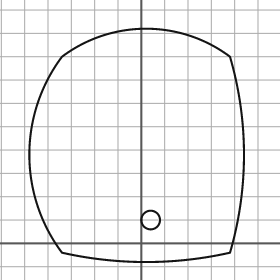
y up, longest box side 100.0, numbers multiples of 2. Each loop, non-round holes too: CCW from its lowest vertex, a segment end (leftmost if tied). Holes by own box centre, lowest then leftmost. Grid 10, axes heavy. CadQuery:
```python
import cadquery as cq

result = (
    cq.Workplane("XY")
    .moveTo(-34.0, -4.0)
    .threePointArc((2.0, -8.0), (38.0, -4.0))
    .threePointArc((44.0, 38.0), (38.0, 80.0))
    .threePointArc((2.0, 92.0), (-34.0, 80.0))
    .threePointArc((-48.0, 38.0), (-34.0, -4.0))
    .close()
    .moveTo(4.0, 10.0)
    .circle(4.0)
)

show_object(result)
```